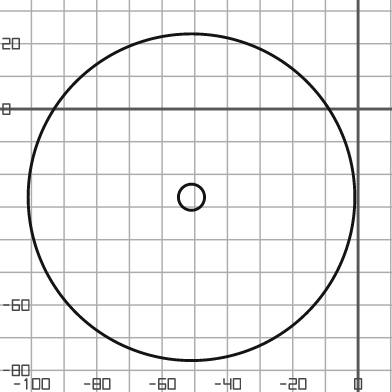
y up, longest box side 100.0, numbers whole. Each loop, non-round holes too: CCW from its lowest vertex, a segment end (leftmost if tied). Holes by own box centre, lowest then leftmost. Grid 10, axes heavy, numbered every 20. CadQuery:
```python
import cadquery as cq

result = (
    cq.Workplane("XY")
    .moveTo(-51.0, -27.0)
    .circle(50.0)
    .moveTo(-51.0, -27.0)
    .circle(4.0)
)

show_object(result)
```